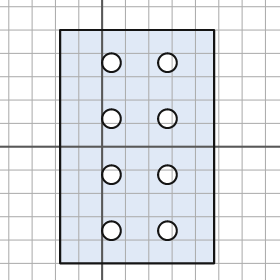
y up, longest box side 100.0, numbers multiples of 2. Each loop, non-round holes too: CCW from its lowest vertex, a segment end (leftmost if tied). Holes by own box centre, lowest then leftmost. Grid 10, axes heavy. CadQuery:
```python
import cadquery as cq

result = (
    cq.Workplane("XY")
    .moveTo(-18.0, -50.0)
    .lineTo(48.0, -50.0)
    .lineTo(48.0, 50.0)
    .lineTo(-18.0, 50.0)
    .close()
    .moveTo(4.0, -36.0)
    .circle(4.0)
    .moveTo(28.0, -36.0)
    .circle(4.0)
    .moveTo(4.0, -12.0)
    .circle(4.0)
    .moveTo(28.0, -12.0)
    .circle(4.0)
    .moveTo(4.0, 12.0)
    .circle(4.0)
    .moveTo(28.0, 12.0)
    .circle(4.0)
    .moveTo(4.0, 36.0)
    .circle(4.0)
    .moveTo(28.0, 36.0)
    .circle(4.0)
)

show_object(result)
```